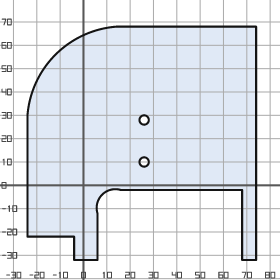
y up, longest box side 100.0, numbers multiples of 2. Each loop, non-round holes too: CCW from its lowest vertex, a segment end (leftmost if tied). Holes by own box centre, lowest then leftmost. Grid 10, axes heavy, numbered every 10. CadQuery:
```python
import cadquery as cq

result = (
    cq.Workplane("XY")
    .moveTo(-4.0, -32.0)
    .lineTo(6.0, -32.0)
    .lineTo(6.0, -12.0)
    .threePointArc((8.0, -4.0), (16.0, -2.0))
    .lineTo(68.0, -2.0)
    .lineTo(68.0, -32.0)
    .lineTo(74.0, -32.0)
    .lineTo(74.0, 68.0)
    .lineTo(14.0, 68.0)
    .threePointArc((-12.0, 56.0), (-24.0, 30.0))
    .lineTo(-24.0, -22.0)
    .lineTo(-4.0, -22.0)
    .close()
    .moveTo(26.0, 10.0)
    .circle(2.0)
    .moveTo(26.0, 28.0)
    .circle(2.0)
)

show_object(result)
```